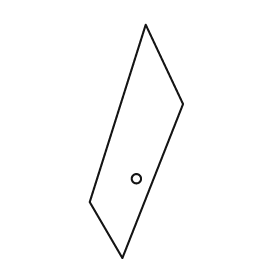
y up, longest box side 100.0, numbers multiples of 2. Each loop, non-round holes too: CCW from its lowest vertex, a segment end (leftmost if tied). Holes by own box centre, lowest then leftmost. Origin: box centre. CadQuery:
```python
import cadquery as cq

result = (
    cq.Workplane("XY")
    .moveTo(-6.0, -50.0)
    .lineTo(20.0, 16.0)
    .lineTo(4.0, 50.0)
    .lineTo(-20.0, -26.0)
    .close()
    .moveTo(0.0, -16.0)
    .circle(2.0)
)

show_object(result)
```